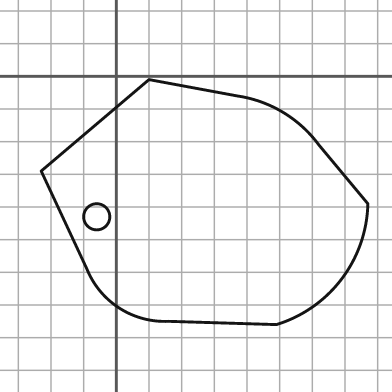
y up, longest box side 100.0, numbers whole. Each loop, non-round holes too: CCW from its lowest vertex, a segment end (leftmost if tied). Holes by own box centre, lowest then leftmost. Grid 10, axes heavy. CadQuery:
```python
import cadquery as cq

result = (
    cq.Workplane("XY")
    .moveTo(49.0, -76.0)
    .threePointArc((69.0, -62.0), (77.0, -39.0))
    .lineTo(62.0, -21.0)
    .threePointArc((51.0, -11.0), (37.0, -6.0))
    .lineTo(10.0, -1.0)
    .lineTo(-23.0, -29.0)
    .lineTo(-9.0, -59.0)
    .threePointArc((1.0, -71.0), (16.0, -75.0))
    .close()
    .moveTo(-6.0, -43.0)
    .circle(4.0)
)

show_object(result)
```